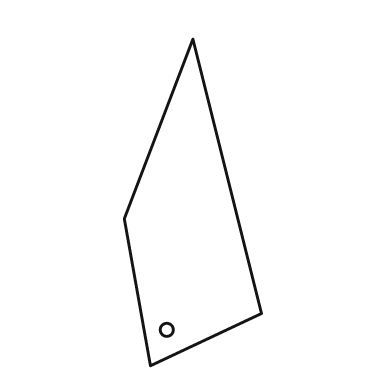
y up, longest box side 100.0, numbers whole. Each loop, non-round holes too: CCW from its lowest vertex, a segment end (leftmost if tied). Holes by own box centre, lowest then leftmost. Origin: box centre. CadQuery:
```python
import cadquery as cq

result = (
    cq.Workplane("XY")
    .moveTo(-13.0, -50.0)
    .lineTo(21.0, -34.0)
    .lineTo(0.0, 50.0)
    .lineTo(-21.0, -5.0)
    .close()
    .moveTo(-8.0, -39.0)
    .circle(2.0)
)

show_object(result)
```